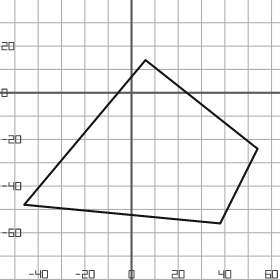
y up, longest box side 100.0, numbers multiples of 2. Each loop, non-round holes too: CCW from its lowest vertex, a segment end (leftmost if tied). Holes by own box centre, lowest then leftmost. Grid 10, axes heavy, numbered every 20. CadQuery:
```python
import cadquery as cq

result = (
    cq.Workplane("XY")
    .moveTo(38.0, -56.0)
    .lineTo(54.0, -24.0)
    .lineTo(6.0, 14.0)
    .lineTo(-46.0, -48.0)
    .close()
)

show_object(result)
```